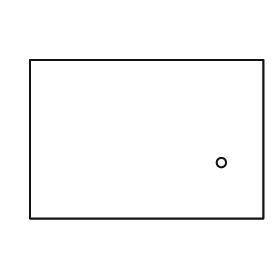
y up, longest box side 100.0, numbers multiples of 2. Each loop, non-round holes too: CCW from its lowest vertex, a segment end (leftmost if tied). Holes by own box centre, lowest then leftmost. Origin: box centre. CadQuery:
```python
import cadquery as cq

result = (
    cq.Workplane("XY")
    .moveTo(-50.0, -34.0)
    .lineTo(50.0, -34.0)
    .lineTo(50.0, 34.0)
    .lineTo(-50.0, 34.0)
    .close()
    .moveTo(32.0, -10.0)
    .circle(2.0)
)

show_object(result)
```